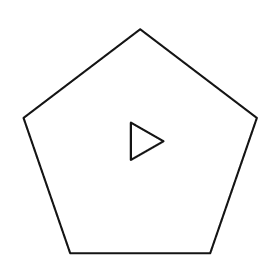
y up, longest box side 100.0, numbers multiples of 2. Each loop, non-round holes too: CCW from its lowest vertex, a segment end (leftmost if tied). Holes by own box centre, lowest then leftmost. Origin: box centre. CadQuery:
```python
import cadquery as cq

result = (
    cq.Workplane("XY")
    .moveTo(-30.0, -48.0)
    .lineTo(30.0, -48.0)
    .lineTo(50.0, 10.0)
    .lineTo(0.0, 48.0)
    .lineTo(-50.0, 10.0)
    .close()
    .moveTo(-4.0, -8.0)
    .lineTo(10.0, 0.0)
    .lineTo(-4.0, 8.0)
    .close()
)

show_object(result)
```